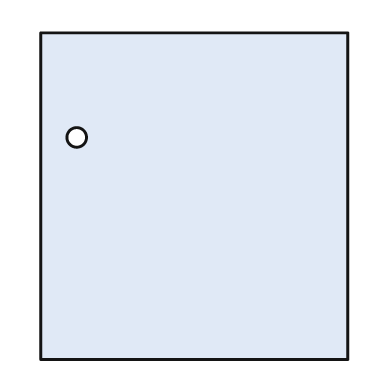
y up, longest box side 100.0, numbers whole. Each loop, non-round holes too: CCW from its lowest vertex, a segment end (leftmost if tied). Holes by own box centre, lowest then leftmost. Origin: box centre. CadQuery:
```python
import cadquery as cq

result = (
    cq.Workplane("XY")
    .moveTo(-47.0, -50.0)
    .lineTo(47.0, -50.0)
    .lineTo(47.0, 50.0)
    .lineTo(-47.0, 50.0)
    .close()
    .moveTo(-36.0, 18.0)
    .circle(3.0)
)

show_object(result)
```